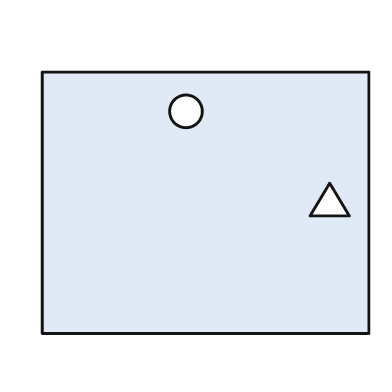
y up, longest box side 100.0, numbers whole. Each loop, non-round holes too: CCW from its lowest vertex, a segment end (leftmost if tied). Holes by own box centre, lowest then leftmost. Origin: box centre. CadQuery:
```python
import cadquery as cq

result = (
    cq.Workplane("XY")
    .moveTo(-50.0, -40.0)
    .lineTo(50.0, -40.0)
    .lineTo(50.0, 40.0)
    .lineTo(-50.0, 40.0)
    .close()
    .moveTo(32.0, -4.0)
    .lineTo(44.0, -4.0)
    .lineTo(38.0, 6.0)
    .close()
    .moveTo(-6.0, 28.0)
    .circle(5.0)
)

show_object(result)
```